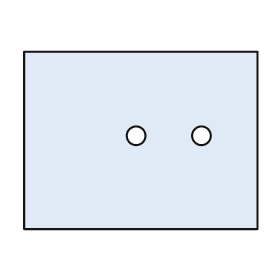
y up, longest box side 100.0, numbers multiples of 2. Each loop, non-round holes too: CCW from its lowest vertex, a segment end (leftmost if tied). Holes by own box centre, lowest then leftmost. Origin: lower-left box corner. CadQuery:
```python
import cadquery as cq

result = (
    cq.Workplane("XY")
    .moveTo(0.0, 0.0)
    .lineTo(100.0, 0.0)
    .lineTo(100.0, 76.0)
    .lineTo(0.0, 76.0)
    .close()
    .moveTo(48.0, 40.0)
    .circle(4.0)
    .moveTo(76.0, 40.0)
    .circle(4.0)
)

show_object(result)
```